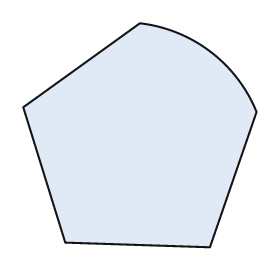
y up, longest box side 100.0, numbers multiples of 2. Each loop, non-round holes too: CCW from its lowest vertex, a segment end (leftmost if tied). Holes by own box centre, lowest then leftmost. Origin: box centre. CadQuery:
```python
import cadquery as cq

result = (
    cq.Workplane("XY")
    .moveTo(30.0, -48.0)
    .lineTo(50.0, 10.0)
    .threePointArc((30.0, 36.0), (0.0, 48.0))
    .lineTo(-50.0, 12.0)
    .lineTo(-32.0, -46.0)
    .close()
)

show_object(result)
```